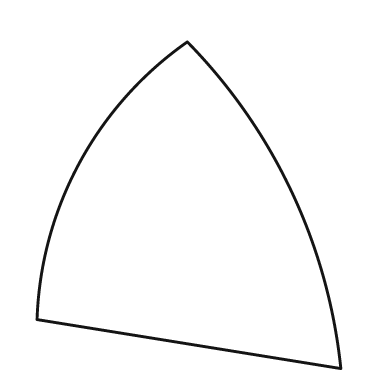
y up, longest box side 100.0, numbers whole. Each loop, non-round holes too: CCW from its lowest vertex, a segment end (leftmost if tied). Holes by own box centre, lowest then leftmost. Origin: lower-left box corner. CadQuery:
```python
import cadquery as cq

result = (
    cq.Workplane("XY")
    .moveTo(93.0, 0.0)
    .threePointArc((78.0, 54.0), (46.0, 100.0))
    .threePointArc((13.0, 63.0), (0.0, 15.0))
    .close()
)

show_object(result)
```